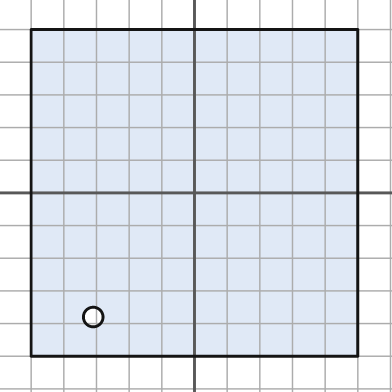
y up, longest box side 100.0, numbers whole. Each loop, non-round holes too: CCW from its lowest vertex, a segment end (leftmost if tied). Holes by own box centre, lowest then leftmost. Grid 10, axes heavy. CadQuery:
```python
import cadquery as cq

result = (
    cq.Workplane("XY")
    .moveTo(-50.0, -50.0)
    .lineTo(50.0, -50.0)
    .lineTo(50.0, 50.0)
    .lineTo(-50.0, 50.0)
    .close()
    .moveTo(-31.0, -38.0)
    .circle(3.0)
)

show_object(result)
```